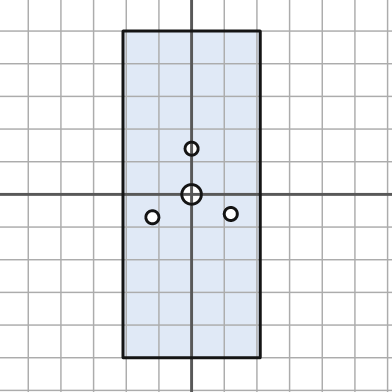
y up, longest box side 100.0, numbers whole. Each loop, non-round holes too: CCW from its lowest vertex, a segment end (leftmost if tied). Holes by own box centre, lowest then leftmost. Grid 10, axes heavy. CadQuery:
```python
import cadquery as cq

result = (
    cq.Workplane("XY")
    .moveTo(-21.0, -50.0)
    .lineTo(21.0, -50.0)
    .lineTo(21.0, 50.0)
    .lineTo(-21.0, 50.0)
    .close()
    .moveTo(-12.0, -7.0)
    .circle(2.0)
    .moveTo(12.0, -6.0)
    .circle(2.0)
    .moveTo(0.0, 0.0)
    .circle(3.0)
    .moveTo(0.0, 14.0)
    .circle(2.0)
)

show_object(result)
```